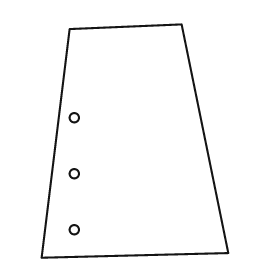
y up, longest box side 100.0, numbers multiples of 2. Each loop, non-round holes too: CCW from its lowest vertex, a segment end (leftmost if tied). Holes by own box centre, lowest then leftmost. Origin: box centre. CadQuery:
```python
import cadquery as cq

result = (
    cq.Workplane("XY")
    .moveTo(-40.0, -50.0)
    .lineTo(40.0, -48.0)
    .lineTo(20.0, 50.0)
    .lineTo(-28.0, 48.0)
    .close()
    .moveTo(-26.0, -38.0)
    .circle(2.0)
    .moveTo(-26.0, -14.0)
    .circle(2.0)
    .moveTo(-26.0, 10.0)
    .circle(2.0)
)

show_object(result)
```